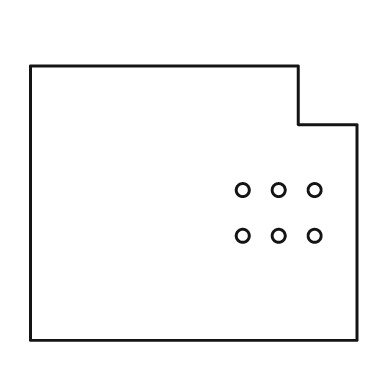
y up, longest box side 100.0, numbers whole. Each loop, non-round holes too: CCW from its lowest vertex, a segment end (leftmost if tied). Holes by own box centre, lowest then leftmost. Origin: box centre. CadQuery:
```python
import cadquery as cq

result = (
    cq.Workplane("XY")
    .moveTo(-50.0, -42.0)
    .lineTo(50.0, -42.0)
    .lineTo(50.0, 24.0)
    .lineTo(32.0, 24.0)
    .lineTo(32.0, 42.0)
    .lineTo(-50.0, 42.0)
    .close()
    .moveTo(15.0, -10.0)
    .circle(2.0)
    .moveTo(26.0, -10.0)
    .circle(2.0)
    .moveTo(37.0, -10.0)
    .circle(2.0)
    .moveTo(15.0, 4.0)
    .circle(2.0)
    .moveTo(26.0, 4.0)
    .circle(2.0)
    .moveTo(37.0, 4.0)
    .circle(2.0)
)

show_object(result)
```